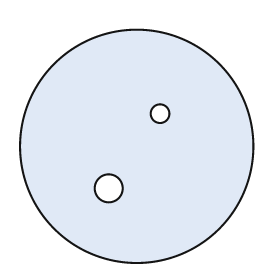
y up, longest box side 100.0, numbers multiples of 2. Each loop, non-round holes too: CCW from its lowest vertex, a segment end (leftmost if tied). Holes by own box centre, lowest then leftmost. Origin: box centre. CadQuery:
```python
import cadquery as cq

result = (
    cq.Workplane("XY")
    .moveTo(0.0, 0.0)
    .circle(50.0)
    .moveTo(-12.0, -18.0)
    .circle(6.0)
    .moveTo(10.0, 14.0)
    .circle(4.0)
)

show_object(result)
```